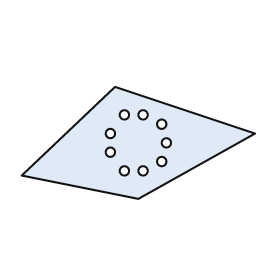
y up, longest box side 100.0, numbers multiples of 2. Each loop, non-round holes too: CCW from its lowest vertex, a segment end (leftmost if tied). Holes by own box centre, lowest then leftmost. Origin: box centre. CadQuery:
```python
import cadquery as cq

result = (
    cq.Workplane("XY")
    .moveTo(0.0, -24.0)
    .lineTo(50.0, 4.0)
    .lineTo(-10.0, 24.0)
    .lineTo(-50.0, -14.0)
    .close()
    .moveTo(-6.0, -12.0)
    .circle(2.0)
    .moveTo(2.0, -12.0)
    .circle(2.0)
    .moveTo(10.0, -8.0)
    .circle(2.0)
    .moveTo(-12.0, -4.0)
    .circle(2.0)
    .moveTo(12.0, 0.0)
    .circle(2.0)
    .moveTo(-12.0, 4.0)
    .circle(2.0)
    .moveTo(10.0, 8.0)
    .circle(2.0)
    .moveTo(-6.0, 12.0)
    .circle(2.0)
    .moveTo(2.0, 12.0)
    .circle(2.0)
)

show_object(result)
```